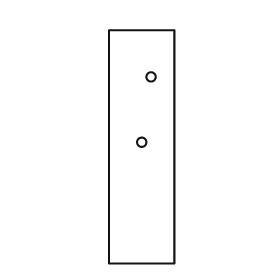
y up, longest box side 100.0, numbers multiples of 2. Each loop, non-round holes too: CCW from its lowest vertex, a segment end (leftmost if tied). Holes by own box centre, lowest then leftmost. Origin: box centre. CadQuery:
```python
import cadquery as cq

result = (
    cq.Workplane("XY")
    .moveTo(-14.0, -50.0)
    .lineTo(14.0, -50.0)
    .lineTo(14.0, 50.0)
    .lineTo(-14.0, 50.0)
    .close()
    .moveTo(0.0, 2.0)
    .circle(2.0)
    .moveTo(4.0, 30.0)
    .circle(2.0)
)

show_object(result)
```